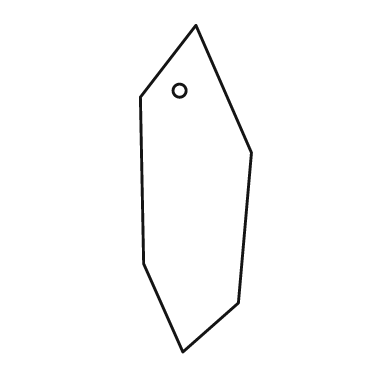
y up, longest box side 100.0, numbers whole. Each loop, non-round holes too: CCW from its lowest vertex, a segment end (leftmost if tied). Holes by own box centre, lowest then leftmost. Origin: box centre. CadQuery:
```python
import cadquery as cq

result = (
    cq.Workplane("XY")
    .moveTo(-4.0, -50.0)
    .lineTo(13.0, -35.0)
    .lineTo(17.0, 11.0)
    .lineTo(0.0, 50.0)
    .lineTo(-17.0, 28.0)
    .lineTo(-16.0, -23.0)
    .close()
    .moveTo(-5.0, 30.0)
    .circle(2.0)
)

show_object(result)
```